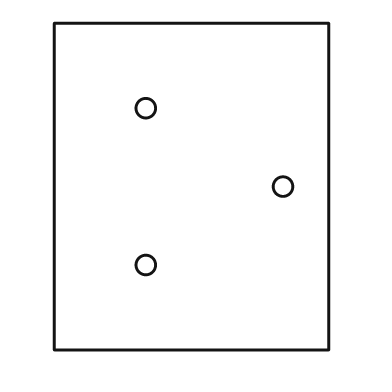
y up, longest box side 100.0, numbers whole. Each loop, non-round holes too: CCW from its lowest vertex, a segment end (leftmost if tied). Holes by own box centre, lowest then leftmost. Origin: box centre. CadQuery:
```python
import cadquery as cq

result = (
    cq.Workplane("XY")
    .moveTo(-42.0, -50.0)
    .lineTo(42.0, -50.0)
    .lineTo(42.0, 50.0)
    .lineTo(-42.0, 50.0)
    .close()
    .moveTo(-14.0, -24.0)
    .circle(3.0)
    .moveTo(28.0, 0.0)
    .circle(3.0)
    .moveTo(-14.0, 24.0)
    .circle(3.0)
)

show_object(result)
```